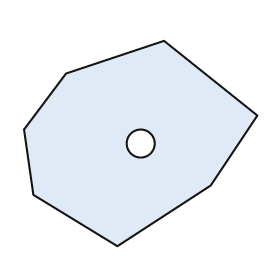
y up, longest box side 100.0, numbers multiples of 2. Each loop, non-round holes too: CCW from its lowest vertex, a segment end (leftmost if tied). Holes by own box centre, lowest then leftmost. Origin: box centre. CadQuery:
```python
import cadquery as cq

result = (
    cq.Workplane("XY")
    .moveTo(-10.0, -44.0)
    .lineTo(30.0, -18.0)
    .lineTo(50.0, 12.0)
    .lineTo(10.0, 44.0)
    .lineTo(-32.0, 30.0)
    .lineTo(-50.0, 6.0)
    .lineTo(-46.0, -22.0)
    .close()
    .moveTo(0.0, 0.0)
    .circle(6.0)
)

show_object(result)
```